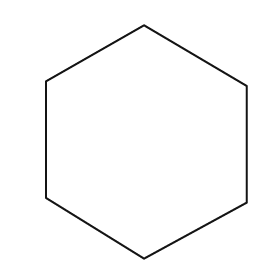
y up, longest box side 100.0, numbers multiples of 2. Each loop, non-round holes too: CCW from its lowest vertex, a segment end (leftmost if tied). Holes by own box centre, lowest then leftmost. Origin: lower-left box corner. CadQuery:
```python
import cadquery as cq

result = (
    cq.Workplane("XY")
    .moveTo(42.0, 0.0)
    .lineTo(86.0, 24.0)
    .lineTo(86.0, 74.0)
    .lineTo(42.0, 100.0)
    .lineTo(0.0, 76.0)
    .lineTo(0.0, 26.0)
    .close()
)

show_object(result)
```